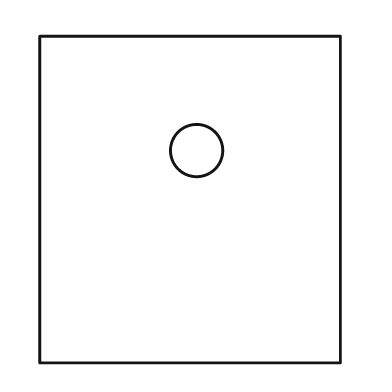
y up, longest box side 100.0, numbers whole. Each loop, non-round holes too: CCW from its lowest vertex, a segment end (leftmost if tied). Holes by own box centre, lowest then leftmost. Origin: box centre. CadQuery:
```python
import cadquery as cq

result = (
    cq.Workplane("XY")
    .moveTo(-46.0, -50.0)
    .lineTo(46.0, -50.0)
    .lineTo(46.0, 50.0)
    .lineTo(-46.0, 50.0)
    .close()
    .moveTo(2.0, 15.0)
    .circle(8.0)
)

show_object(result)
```